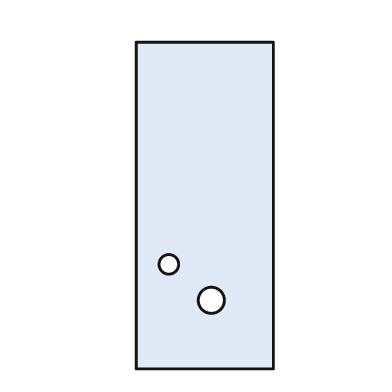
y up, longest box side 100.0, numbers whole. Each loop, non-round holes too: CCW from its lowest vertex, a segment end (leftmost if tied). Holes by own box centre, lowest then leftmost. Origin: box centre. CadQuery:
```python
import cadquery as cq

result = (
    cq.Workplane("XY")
    .moveTo(-21.0, -50.0)
    .lineTo(21.0, -50.0)
    .lineTo(21.0, 50.0)
    .lineTo(-21.0, 50.0)
    .close()
    .moveTo(2.0, -29.0)
    .circle(4.0)
    .moveTo(-11.0, -18.0)
    .circle(3.0)
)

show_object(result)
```